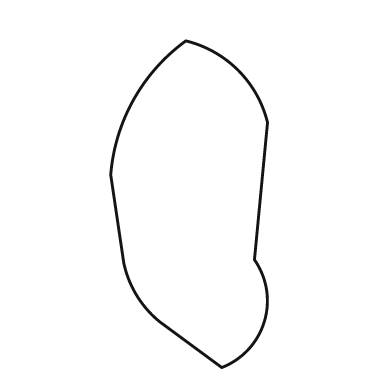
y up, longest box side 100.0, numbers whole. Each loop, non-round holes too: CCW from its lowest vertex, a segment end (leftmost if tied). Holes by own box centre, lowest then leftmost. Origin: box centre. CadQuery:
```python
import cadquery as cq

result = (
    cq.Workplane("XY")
    .moveTo(10.0, -50.0)
    .threePointArc((23.0, -36.0), (20.0, -17.0))
    .lineTo(24.0, 25.0)
    .threePointArc((15.0, 41.0), (-1.0, 50.0))
    .threePointArc((-17.0, 32.0), (-24.0, 9.0))
    .lineTo(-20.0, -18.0)
    .threePointArc((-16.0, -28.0), (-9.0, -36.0))
    .close()
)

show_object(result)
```